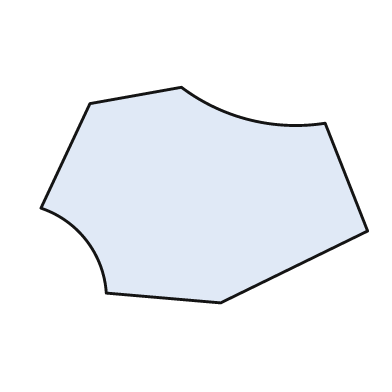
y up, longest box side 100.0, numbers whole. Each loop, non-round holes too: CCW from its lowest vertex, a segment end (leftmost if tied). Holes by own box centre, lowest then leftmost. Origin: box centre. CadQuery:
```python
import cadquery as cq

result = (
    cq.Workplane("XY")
    .moveTo(5.0, -33.0)
    .lineTo(50.0, -11.0)
    .lineTo(37.0, 22.0)
    .threePointArc((14.0, 23.0), (-7.0, 33.0))
    .lineTo(-35.0, 28.0)
    .lineTo(-50.0, -4.0)
    .threePointArc((-36.0, -14.0), (-30.0, -30.0))
    .close()
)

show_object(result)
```